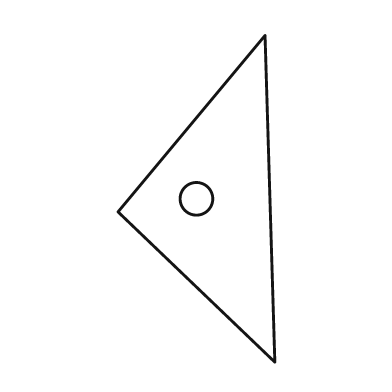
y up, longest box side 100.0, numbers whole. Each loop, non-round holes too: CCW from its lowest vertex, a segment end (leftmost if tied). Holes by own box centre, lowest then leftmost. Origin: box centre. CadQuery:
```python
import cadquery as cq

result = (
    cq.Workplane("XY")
    .moveTo(24.0, -50.0)
    .lineTo(21.0, 50.0)
    .lineTo(-24.0, -4.0)
    .close()
    .moveTo(0.0, 0.0)
    .circle(5.0)
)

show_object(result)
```